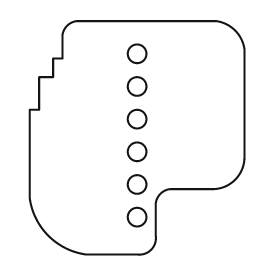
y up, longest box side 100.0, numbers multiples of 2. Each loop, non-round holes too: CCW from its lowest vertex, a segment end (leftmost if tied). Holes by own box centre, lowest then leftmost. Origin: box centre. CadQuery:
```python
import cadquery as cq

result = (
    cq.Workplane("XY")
    .moveTo(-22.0, -50.0)
    .lineTo(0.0, -50.0)
    .threePointArc((6.0, -48.0), (8.0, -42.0))
    .lineTo(8.0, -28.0)
    .threePointArc((10.0, -24.0), (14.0, -22.0))
    .lineTo(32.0, -22.0)
    .threePointArc((42.0, -18.0), (46.0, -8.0))
    .lineTo(46.0, 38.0)
    .threePointArc((42.0, 46.0), (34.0, 50.0))
    .lineTo(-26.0, 50.0)
    .threePointArc((-30.0, 48.0), (-32.0, 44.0))
    .lineTo(-32.0, 34.0)
    .lineTo(-36.0, 34.0)
    .lineTo(-36.0, 26.0)
    .lineTo(-42.0, 26.0)
    .lineTo(-42.0, 12.0)
    .lineTo(-46.0, 12.0)
    .lineTo(-46.0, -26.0)
    .threePointArc((-38.0, -42.0), (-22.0, -50.0))
    .close()
    .moveTo(0.0, -34.0)
    .circle(4.0)
    .moveTo(0.0, -20.0)
    .circle(4.0)
    .moveTo(0.0, -6.0)
    .circle(4.0)
    .moveTo(0.0, 8.0)
    .circle(4.0)
    .moveTo(0.0, 22.0)
    .circle(4.0)
    .moveTo(0.0, 36.0)
    .circle(4.0)
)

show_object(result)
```